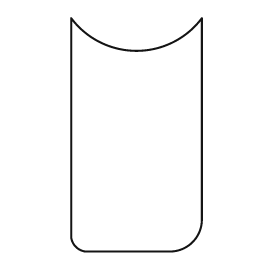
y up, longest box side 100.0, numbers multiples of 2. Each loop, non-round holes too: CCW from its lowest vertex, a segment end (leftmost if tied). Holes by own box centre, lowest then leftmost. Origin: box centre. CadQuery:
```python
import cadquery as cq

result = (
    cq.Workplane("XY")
    .moveTo(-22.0, -50.0)
    .lineTo(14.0, -50.0)
    .threePointArc((24.0, -46.0), (28.0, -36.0))
    .lineTo(28.0, 50.0)
    .threePointArc((0.0, 36.0), (-28.0, 50.0))
    .lineTo(-28.0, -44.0)
    .threePointArc((-26.0, -48.0), (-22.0, -50.0))
    .close()
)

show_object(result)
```